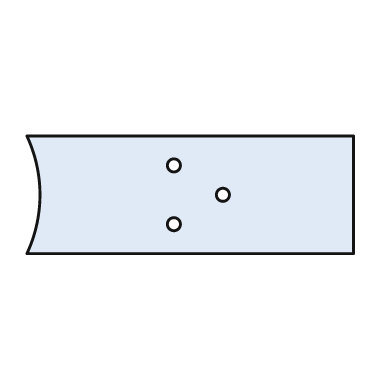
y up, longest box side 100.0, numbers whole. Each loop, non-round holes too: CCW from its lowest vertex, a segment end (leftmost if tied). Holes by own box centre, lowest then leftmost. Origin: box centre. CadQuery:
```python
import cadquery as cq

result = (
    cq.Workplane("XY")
    .moveTo(-50.0, -18.0)
    .lineTo(50.0, -18.0)
    .lineTo(50.0, 18.0)
    .lineTo(-50.0, 18.0)
    .threePointArc((-46.0, 0.0), (-50.0, -18.0))
    .close()
    .moveTo(-5.0, -9.0)
    .circle(2.0)
    .moveTo(10.0, 0.0)
    .circle(2.0)
    .moveTo(-5.0, 9.0)
    .circle(2.0)
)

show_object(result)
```